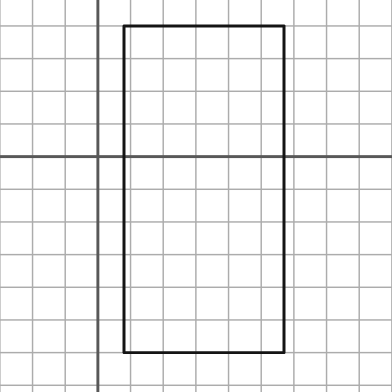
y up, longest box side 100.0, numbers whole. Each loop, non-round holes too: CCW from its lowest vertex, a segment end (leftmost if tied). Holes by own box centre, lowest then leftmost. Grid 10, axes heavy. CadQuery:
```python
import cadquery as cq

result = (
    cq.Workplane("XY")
    .moveTo(8.0, -60.0)
    .lineTo(57.0, -60.0)
    .lineTo(57.0, 40.0)
    .lineTo(8.0, 40.0)
    .close()
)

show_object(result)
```